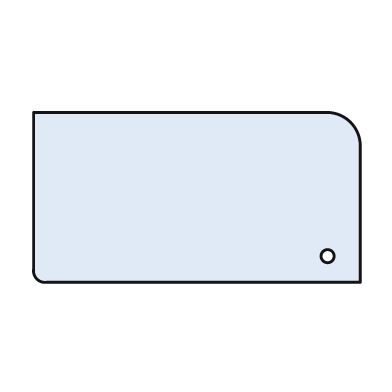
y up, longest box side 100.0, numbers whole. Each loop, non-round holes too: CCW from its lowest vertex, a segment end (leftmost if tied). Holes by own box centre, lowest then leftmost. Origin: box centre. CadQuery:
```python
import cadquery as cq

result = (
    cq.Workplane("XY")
    .moveTo(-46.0, -26.0)
    .lineTo(50.0, -26.0)
    .lineTo(50.0, 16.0)
    .threePointArc((47.0, 23.0), (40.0, 26.0))
    .lineTo(-50.0, 26.0)
    .lineTo(-50.0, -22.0)
    .threePointArc((-49.0, -25.0), (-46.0, -26.0))
    .close()
    .moveTo(40.0, -18.0)
    .circle(2.0)
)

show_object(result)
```